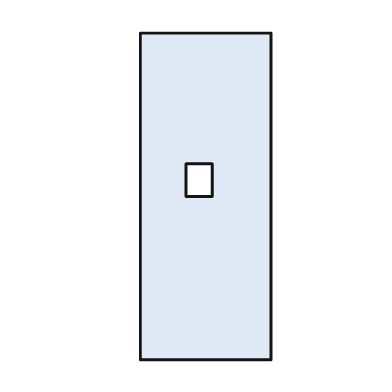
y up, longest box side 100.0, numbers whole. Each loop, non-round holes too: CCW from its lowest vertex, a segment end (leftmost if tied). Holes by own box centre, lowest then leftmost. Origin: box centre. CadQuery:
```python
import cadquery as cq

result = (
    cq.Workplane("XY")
    .moveTo(-20.0, -50.0)
    .lineTo(20.0, -50.0)
    .lineTo(20.0, 50.0)
    .lineTo(-20.0, 50.0)
    .close()
    .moveTo(-6.0, 0.0)
    .lineTo(2.0, 0.0)
    .lineTo(2.0, 10.0)
    .lineTo(-6.0, 10.0)
    .close()
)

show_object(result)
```